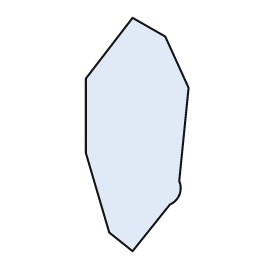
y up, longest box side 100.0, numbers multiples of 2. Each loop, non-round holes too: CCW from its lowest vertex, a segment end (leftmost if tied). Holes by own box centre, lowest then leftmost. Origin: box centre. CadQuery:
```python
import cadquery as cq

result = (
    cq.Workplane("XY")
    .moveTo(-2.0, -50.0)
    .lineTo(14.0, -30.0)
    .threePointArc((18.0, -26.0), (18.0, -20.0))
    .lineTo(22.0, 20.0)
    .lineTo(12.0, 42.0)
    .lineTo(-2.0, 50.0)
    .lineTo(-22.0, 24.0)
    .lineTo(-22.0, -8.0)
    .lineTo(-12.0, -42.0)
    .close()
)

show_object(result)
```